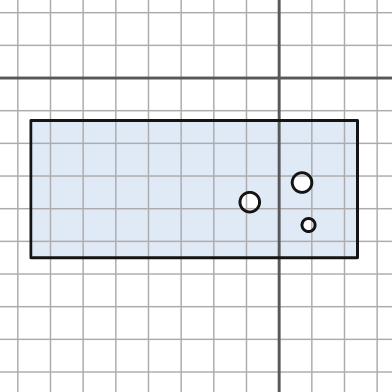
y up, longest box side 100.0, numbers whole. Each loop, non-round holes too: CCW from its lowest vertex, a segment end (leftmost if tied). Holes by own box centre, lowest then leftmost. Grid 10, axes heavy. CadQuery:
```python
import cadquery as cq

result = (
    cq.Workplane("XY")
    .moveTo(-76.0, -55.0)
    .lineTo(24.0, -55.0)
    .lineTo(24.0, -13.0)
    .lineTo(-76.0, -13.0)
    .close()
    .moveTo(9.0, -45.0)
    .circle(2.0)
    .moveTo(-9.0, -38.0)
    .circle(3.0)
    .moveTo(7.0, -32.0)
    .circle(3.0)
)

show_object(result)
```